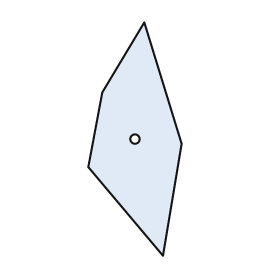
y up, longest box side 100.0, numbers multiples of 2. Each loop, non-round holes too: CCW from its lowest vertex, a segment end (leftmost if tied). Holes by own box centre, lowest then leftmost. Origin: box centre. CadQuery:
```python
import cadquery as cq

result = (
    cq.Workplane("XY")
    .moveTo(12.0, -50.0)
    .lineTo(20.0, -2.0)
    .lineTo(4.0, 50.0)
    .lineTo(-14.0, 20.0)
    .lineTo(-20.0, -12.0)
    .close()
    .moveTo(0.0, 0.0)
    .circle(2.0)
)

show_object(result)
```